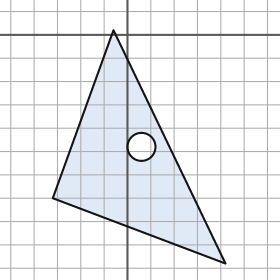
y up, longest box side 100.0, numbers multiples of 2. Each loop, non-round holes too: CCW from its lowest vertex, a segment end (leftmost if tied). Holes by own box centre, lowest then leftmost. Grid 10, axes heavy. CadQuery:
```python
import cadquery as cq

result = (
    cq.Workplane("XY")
    .moveTo(42.0, -98.0)
    .lineTo(-6.0, 2.0)
    .lineTo(-32.0, -70.0)
    .close()
    .moveTo(6.0, -48.0)
    .circle(6.0)
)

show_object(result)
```